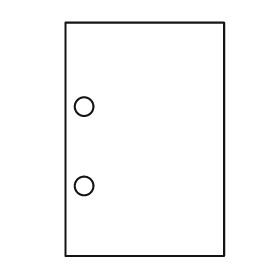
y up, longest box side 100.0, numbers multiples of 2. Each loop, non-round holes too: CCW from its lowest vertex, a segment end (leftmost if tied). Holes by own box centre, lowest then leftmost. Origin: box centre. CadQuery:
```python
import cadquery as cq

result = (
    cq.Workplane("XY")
    .moveTo(-34.0, -50.0)
    .lineTo(34.0, -50.0)
    .lineTo(34.0, 50.0)
    .lineTo(-34.0, 50.0)
    .close()
    .moveTo(-26.0, -20.0)
    .circle(4.0)
    .moveTo(-26.0, 14.0)
    .circle(4.0)
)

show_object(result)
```